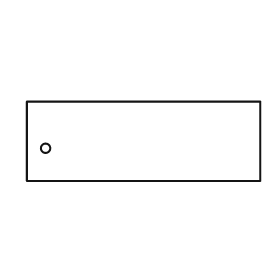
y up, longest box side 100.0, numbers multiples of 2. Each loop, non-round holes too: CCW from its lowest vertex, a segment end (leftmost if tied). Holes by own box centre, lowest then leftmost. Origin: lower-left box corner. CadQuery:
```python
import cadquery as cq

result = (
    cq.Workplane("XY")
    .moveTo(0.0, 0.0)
    .lineTo(100.0, 0.0)
    .lineTo(100.0, 34.0)
    .lineTo(0.0, 34.0)
    .close()
    .moveTo(8.0, 14.0)
    .circle(2.0)
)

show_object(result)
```